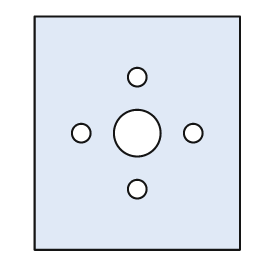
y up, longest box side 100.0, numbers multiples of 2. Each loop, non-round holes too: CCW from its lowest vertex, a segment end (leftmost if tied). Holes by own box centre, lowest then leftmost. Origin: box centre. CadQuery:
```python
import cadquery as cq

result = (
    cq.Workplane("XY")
    .moveTo(-44.0, -50.0)
    .lineTo(44.0, -50.0)
    .lineTo(44.0, 50.0)
    .lineTo(-44.0, 50.0)
    .close()
    .moveTo(0.0, -24.0)
    .circle(4.0)
    .moveTo(-24.0, 0.0)
    .circle(4.0)
    .moveTo(0.0, 0.0)
    .circle(10.0)
    .moveTo(24.0, 0.0)
    .circle(4.0)
    .moveTo(0.0, 24.0)
    .circle(4.0)
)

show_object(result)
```